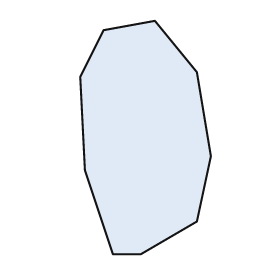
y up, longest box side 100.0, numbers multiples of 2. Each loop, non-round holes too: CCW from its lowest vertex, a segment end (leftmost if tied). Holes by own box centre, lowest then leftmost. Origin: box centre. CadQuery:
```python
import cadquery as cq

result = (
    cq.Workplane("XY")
    .moveTo(-14.0, -50.0)
    .lineTo(-2.0, -50.0)
    .lineTo(22.0, -36.0)
    .lineTo(28.0, -8.0)
    .lineTo(22.0, 28.0)
    .lineTo(4.0, 50.0)
    .lineTo(-18.0, 46.0)
    .lineTo(-28.0, 26.0)
    .lineTo(-26.0, -14.0)
    .close()
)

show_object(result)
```